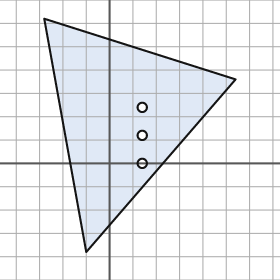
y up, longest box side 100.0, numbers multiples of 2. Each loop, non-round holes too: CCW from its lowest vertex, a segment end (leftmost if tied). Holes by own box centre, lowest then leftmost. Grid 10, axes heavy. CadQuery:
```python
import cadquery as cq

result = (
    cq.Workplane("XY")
    .moveTo(-10.0, -38.0)
    .lineTo(54.0, 36.0)
    .lineTo(-28.0, 62.0)
    .close()
    .moveTo(14.0, 0.0)
    .circle(2.0)
    .moveTo(14.0, 12.0)
    .circle(2.0)
    .moveTo(14.0, 24.0)
    .circle(2.0)
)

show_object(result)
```